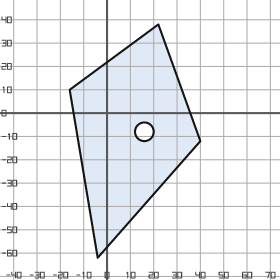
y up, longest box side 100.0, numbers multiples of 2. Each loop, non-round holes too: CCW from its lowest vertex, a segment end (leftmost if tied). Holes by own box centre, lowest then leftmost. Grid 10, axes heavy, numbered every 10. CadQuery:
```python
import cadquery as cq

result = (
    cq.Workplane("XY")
    .moveTo(-4.0, -62.0)
    .lineTo(40.0, -12.0)
    .lineTo(22.0, 38.0)
    .lineTo(-16.0, 10.0)
    .close()
    .moveTo(16.0, -8.0)
    .circle(4.0)
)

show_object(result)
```